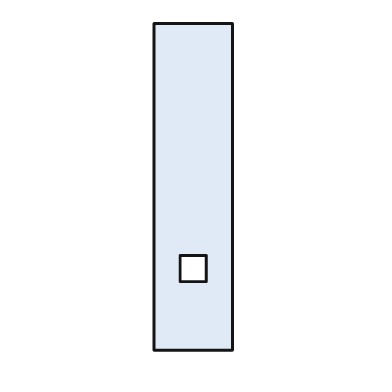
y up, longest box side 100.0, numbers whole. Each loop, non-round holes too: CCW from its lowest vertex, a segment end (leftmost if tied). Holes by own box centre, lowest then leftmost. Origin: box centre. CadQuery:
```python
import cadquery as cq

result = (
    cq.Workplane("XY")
    .moveTo(-12.0, -50.0)
    .lineTo(12.0, -50.0)
    .lineTo(12.0, 50.0)
    .lineTo(-12.0, 50.0)
    .close()
    .moveTo(-4.0, -29.0)
    .lineTo(4.0, -29.0)
    .lineTo(4.0, -21.0)
    .lineTo(-4.0, -21.0)
    .close()
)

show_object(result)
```